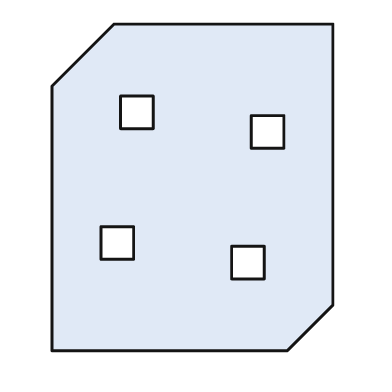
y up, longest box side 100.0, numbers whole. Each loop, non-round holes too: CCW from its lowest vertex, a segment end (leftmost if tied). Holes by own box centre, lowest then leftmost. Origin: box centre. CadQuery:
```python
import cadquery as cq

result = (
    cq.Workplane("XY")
    .moveTo(-43.0, -50.0)
    .lineTo(29.0, -50.0)
    .lineTo(43.0, -36.0)
    .lineTo(43.0, 50.0)
    .lineTo(-24.0, 50.0)
    .lineTo(-43.0, 31.0)
    .close()
    .moveTo(12.0, -28.0)
    .lineTo(22.0, -28.0)
    .lineTo(22.0, -18.0)
    .lineTo(12.0, -18.0)
    .close()
    .moveTo(-28.0, -22.0)
    .lineTo(-18.0, -22.0)
    .lineTo(-18.0, -12.0)
    .lineTo(-28.0, -12.0)
    .close()
    .moveTo(18.0, 12.0)
    .lineTo(28.0, 12.0)
    .lineTo(28.0, 22.0)
    .lineTo(18.0, 22.0)
    .close()
    .moveTo(-22.0, 18.0)
    .lineTo(-12.0, 18.0)
    .lineTo(-12.0, 28.0)
    .lineTo(-22.0, 28.0)
    .close()
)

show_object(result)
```